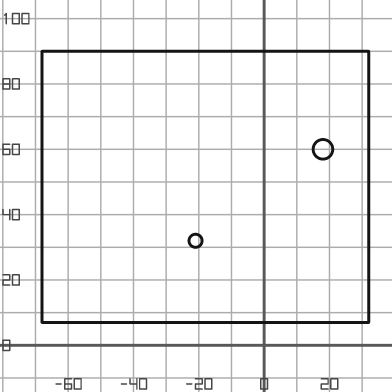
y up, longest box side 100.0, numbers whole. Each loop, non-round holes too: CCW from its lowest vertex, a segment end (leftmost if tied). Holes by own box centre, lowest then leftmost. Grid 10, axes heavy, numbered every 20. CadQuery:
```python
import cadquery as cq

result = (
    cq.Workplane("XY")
    .moveTo(-68.0, 7.0)
    .lineTo(32.0, 7.0)
    .lineTo(32.0, 90.0)
    .lineTo(-68.0, 90.0)
    .close()
    .moveTo(-21.0, 32.0)
    .circle(2.0)
    .moveTo(18.0, 60.0)
    .circle(3.0)
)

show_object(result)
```